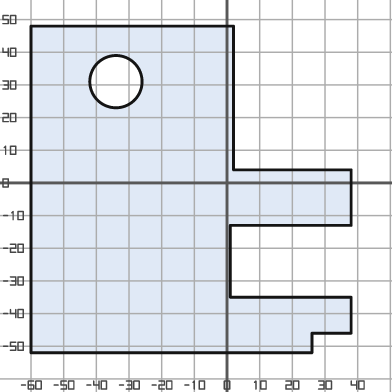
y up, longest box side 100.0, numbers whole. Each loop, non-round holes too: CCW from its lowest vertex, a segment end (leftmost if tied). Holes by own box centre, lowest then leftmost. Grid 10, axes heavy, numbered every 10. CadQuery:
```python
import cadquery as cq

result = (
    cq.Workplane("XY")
    .moveTo(-60.0, -52.0)
    .lineTo(26.0, -52.0)
    .lineTo(26.0, -46.0)
    .lineTo(38.0, -46.0)
    .lineTo(38.0, -35.0)
    .lineTo(1.0, -35.0)
    .lineTo(1.0, -13.0)
    .lineTo(38.0, -13.0)
    .lineTo(38.0, 4.0)
    .lineTo(2.0, 4.0)
    .lineTo(2.0, 48.0)
    .lineTo(-60.0, 48.0)
    .close()
    .moveTo(-34.0, 31.0)
    .circle(8.0)
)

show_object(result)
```